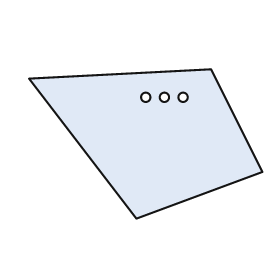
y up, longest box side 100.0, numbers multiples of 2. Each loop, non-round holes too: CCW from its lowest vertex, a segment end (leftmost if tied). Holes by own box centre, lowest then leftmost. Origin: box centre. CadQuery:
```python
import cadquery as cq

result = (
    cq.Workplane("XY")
    .moveTo(-4.0, -32.0)
    .lineTo(50.0, -12.0)
    .lineTo(28.0, 32.0)
    .lineTo(-50.0, 28.0)
    .close()
    .moveTo(0.0, 20.0)
    .circle(2.0)
    .moveTo(8.0, 20.0)
    .circle(2.0)
    .moveTo(16.0, 20.0)
    .circle(2.0)
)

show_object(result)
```